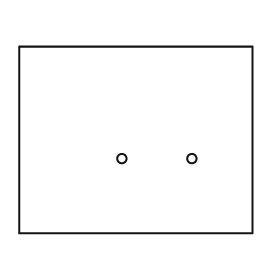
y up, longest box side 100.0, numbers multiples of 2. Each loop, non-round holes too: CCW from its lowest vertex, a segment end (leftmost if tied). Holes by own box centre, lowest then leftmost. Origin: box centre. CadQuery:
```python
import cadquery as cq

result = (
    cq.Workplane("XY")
    .moveTo(-50.0, -40.0)
    .lineTo(50.0, -40.0)
    .lineTo(50.0, 40.0)
    .lineTo(-50.0, 40.0)
    .close()
    .moveTo(-6.0, -8.0)
    .circle(2.0)
    .moveTo(24.0, -8.0)
    .circle(2.0)
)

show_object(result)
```